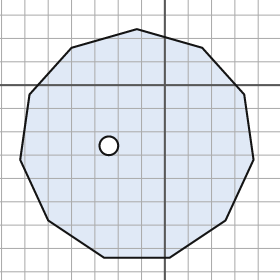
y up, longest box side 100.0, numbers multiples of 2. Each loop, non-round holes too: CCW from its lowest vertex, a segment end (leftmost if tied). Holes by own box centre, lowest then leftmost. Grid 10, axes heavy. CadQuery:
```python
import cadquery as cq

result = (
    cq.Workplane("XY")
    .moveTo(-26.0, -74.0)
    .lineTo(2.0, -74.0)
    .lineTo(26.0, -58.0)
    .lineTo(38.0, -32.0)
    .lineTo(34.0, -4.0)
    .lineTo(16.0, 16.0)
    .lineTo(-12.0, 24.0)
    .lineTo(-40.0, 16.0)
    .lineTo(-58.0, -4.0)
    .lineTo(-62.0, -32.0)
    .lineTo(-50.0, -58.0)
    .close()
    .moveTo(-24.0, -26.0)
    .circle(4.0)
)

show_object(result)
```